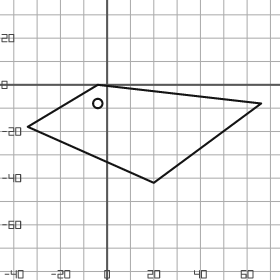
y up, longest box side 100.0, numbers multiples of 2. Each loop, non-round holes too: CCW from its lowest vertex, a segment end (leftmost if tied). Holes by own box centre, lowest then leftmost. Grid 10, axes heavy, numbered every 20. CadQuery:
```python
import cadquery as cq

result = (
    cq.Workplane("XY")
    .moveTo(20.0, -42.0)
    .lineTo(66.0, -8.0)
    .lineTo(-4.0, 0.0)
    .lineTo(-34.0, -18.0)
    .close()
    .moveTo(-4.0, -8.0)
    .circle(2.0)
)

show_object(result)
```